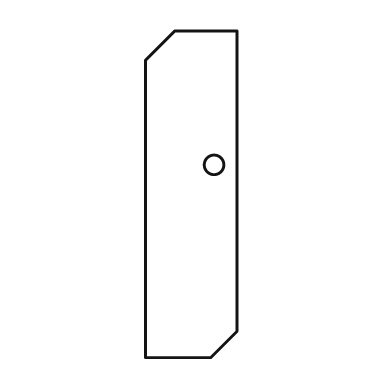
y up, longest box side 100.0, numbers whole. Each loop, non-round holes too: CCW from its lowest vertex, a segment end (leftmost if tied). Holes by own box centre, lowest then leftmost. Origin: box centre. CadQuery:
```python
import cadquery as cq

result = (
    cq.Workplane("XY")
    .moveTo(-14.0, -50.0)
    .lineTo(6.0, -50.0)
    .lineTo(14.0, -42.0)
    .lineTo(14.0, 50.0)
    .lineTo(-5.0, 50.0)
    .lineTo(-14.0, 41.0)
    .close()
    .moveTo(7.0, 9.0)
    .circle(3.0)
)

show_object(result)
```